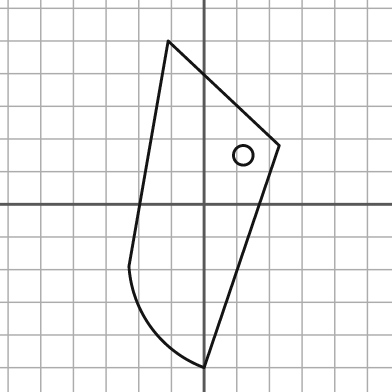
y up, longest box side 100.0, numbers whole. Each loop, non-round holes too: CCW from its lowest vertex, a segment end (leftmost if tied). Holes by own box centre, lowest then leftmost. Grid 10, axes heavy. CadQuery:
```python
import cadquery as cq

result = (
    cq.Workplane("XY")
    .moveTo(0.0, -50.0)
    .lineTo(23.0, 18.0)
    .lineTo(-11.0, 50.0)
    .lineTo(-23.0, -19.0)
    .threePointArc((-16.0, -38.0), (0.0, -50.0))
    .close()
    .moveTo(12.0, 15.0)
    .circle(3.0)
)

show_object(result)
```